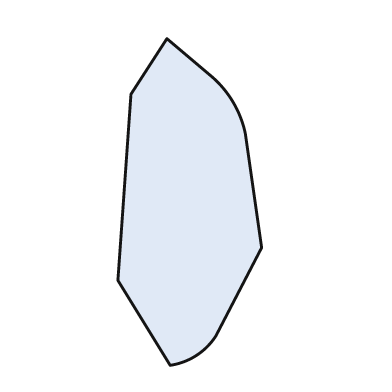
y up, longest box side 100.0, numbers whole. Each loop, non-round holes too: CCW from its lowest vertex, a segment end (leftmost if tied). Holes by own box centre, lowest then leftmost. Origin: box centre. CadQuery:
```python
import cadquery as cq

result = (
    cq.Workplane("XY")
    .moveTo(-6.0, -50.0)
    .threePointArc((2.0, -47.0), (8.0, -41.0))
    .lineTo(22.0, -14.0)
    .lineTo(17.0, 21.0)
    .threePointArc((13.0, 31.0), (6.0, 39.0))
    .lineTo(-7.0, 50.0)
    .lineTo(-18.0, 33.0)
    .lineTo(-22.0, -24.0)
    .close()
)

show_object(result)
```